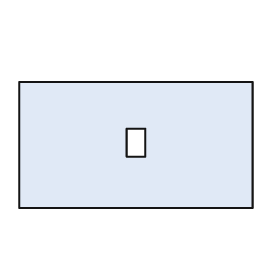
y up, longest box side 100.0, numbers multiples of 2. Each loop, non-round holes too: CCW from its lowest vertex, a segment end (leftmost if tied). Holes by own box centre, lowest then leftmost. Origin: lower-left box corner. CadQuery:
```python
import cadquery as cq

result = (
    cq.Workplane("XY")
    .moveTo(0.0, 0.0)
    .lineTo(100.0, 0.0)
    .lineTo(100.0, 54.0)
    .lineTo(0.0, 54.0)
    .close()
    .moveTo(46.0, 22.0)
    .lineTo(54.0, 22.0)
    .lineTo(54.0, 34.0)
    .lineTo(46.0, 34.0)
    .close()
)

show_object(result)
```